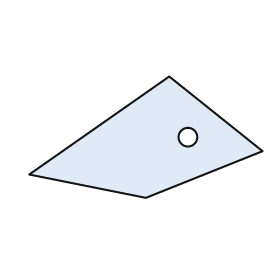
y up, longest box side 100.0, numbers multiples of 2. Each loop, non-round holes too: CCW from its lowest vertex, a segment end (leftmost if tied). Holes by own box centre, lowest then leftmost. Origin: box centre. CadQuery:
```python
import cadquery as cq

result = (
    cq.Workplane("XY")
    .moveTo(0.0, -26.0)
    .lineTo(50.0, -6.0)
    .lineTo(10.0, 26.0)
    .lineTo(-50.0, -16.0)
    .close()
    .moveTo(18.0, 0.0)
    .circle(4.0)
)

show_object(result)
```